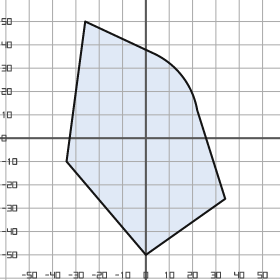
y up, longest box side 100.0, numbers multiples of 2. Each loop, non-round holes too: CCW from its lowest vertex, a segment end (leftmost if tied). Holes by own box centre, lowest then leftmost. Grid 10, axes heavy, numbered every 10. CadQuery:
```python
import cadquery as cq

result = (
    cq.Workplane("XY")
    .moveTo(0.0, -50.0)
    .lineTo(34.0, -26.0)
    .lineTo(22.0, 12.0)
    .threePointArc((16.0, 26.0), (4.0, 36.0))
    .lineTo(-26.0, 50.0)
    .lineTo(-34.0, -10.0)
    .close()
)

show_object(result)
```